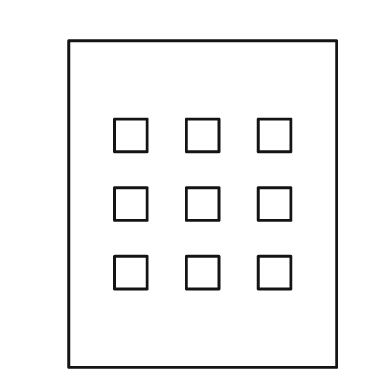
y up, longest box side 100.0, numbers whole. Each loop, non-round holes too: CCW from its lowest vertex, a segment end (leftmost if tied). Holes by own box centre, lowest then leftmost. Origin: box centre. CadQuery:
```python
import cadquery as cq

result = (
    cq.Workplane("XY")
    .moveTo(-41.0, -50.0)
    .lineTo(41.0, -50.0)
    .lineTo(41.0, 50.0)
    .lineTo(-41.0, 50.0)
    .close()
    .moveTo(-27.0, -26.0)
    .lineTo(-17.0, -26.0)
    .lineTo(-17.0, -16.0)
    .lineTo(-27.0, -16.0)
    .close()
    .moveTo(-5.0, -26.0)
    .lineTo(5.0, -26.0)
    .lineTo(5.0, -16.0)
    .lineTo(-5.0, -16.0)
    .close()
    .moveTo(17.0, -26.0)
    .lineTo(27.0, -26.0)
    .lineTo(27.0, -16.0)
    .lineTo(17.0, -16.0)
    .close()
    .moveTo(-27.0, -5.0)
    .lineTo(-17.0, -5.0)
    .lineTo(-17.0, 5.0)
    .lineTo(-27.0, 5.0)
    .close()
    .moveTo(-5.0, -5.0)
    .lineTo(5.0, -5.0)
    .lineTo(5.0, 5.0)
    .lineTo(-5.0, 5.0)
    .close()
    .moveTo(17.0, -5.0)
    .lineTo(27.0, -5.0)
    .lineTo(27.0, 5.0)
    .lineTo(17.0, 5.0)
    .close()
    .moveTo(-27.0, 16.0)
    .lineTo(-17.0, 16.0)
    .lineTo(-17.0, 26.0)
    .lineTo(-27.0, 26.0)
    .close()
    .moveTo(-5.0, 16.0)
    .lineTo(5.0, 16.0)
    .lineTo(5.0, 26.0)
    .lineTo(-5.0, 26.0)
    .close()
    .moveTo(17.0, 16.0)
    .lineTo(27.0, 16.0)
    .lineTo(27.0, 26.0)
    .lineTo(17.0, 26.0)
    .close()
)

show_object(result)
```